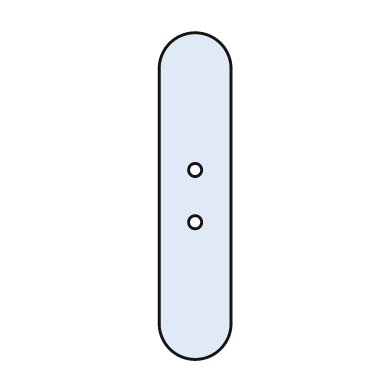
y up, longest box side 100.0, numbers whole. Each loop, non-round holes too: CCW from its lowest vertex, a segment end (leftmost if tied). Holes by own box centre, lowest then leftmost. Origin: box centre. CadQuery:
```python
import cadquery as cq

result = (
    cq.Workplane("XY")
    .moveTo(-11.0, -39.0)
    .threePointArc((0.0, -50.0), (11.0, -39.0))
    .lineTo(11.0, 39.0)
    .threePointArc((0.0, 50.0), (-11.0, 39.0))
    .close()
    .moveTo(0.0, -8.0)
    .circle(2.0)
    .moveTo(0.0, 8.0)
    .circle(2.0)
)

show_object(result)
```